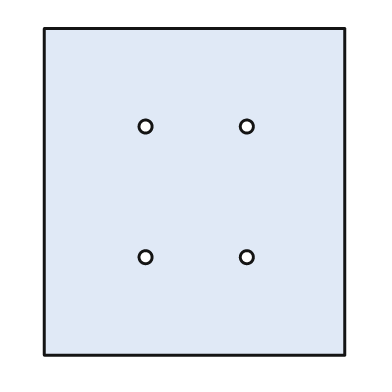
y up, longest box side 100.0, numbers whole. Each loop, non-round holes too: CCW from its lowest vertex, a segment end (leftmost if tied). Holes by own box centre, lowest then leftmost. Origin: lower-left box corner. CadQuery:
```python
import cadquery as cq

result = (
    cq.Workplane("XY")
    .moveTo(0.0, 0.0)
    .lineTo(92.0, 0.0)
    .lineTo(92.0, 100.0)
    .lineTo(0.0, 100.0)
    .close()
    .moveTo(31.0, 30.0)
    .circle(2.0)
    .moveTo(62.0, 30.0)
    .circle(2.0)
    .moveTo(31.0, 70.0)
    .circle(2.0)
    .moveTo(62.0, 70.0)
    .circle(2.0)
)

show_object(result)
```